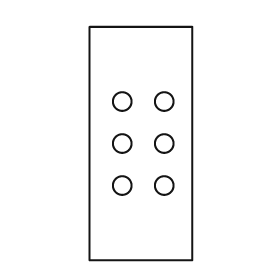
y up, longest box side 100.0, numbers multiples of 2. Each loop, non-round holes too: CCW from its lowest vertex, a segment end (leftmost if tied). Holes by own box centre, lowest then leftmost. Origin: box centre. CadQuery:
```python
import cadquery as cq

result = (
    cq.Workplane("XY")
    .moveTo(-22.0, -50.0)
    .lineTo(22.0, -50.0)
    .lineTo(22.0, 50.0)
    .lineTo(-22.0, 50.0)
    .close()
    .moveTo(-8.0, -18.0)
    .circle(4.0)
    .moveTo(10.0, -18.0)
    .circle(4.0)
    .moveTo(-8.0, 0.0)
    .circle(4.0)
    .moveTo(10.0, 0.0)
    .circle(4.0)
    .moveTo(-8.0, 18.0)
    .circle(4.0)
    .moveTo(10.0, 18.0)
    .circle(4.0)
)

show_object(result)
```